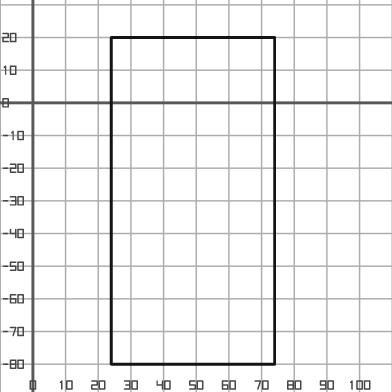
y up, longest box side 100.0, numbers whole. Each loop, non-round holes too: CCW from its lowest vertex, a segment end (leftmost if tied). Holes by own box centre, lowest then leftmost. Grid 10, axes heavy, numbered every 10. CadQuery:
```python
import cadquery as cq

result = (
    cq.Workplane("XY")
    .moveTo(24.0, -80.0)
    .lineTo(74.0, -80.0)
    .lineTo(74.0, 20.0)
    .lineTo(24.0, 20.0)
    .close()
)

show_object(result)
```